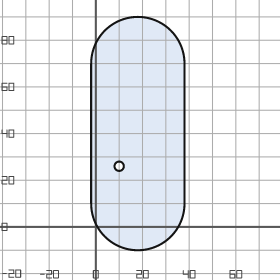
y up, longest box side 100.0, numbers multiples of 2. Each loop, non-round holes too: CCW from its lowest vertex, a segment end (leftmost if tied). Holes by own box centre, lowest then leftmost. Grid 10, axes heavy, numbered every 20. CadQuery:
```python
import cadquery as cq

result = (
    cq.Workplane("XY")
    .moveTo(-2.0, 10.0)
    .threePointArc((18.0, -10.0), (38.0, 10.0))
    .lineTo(38.0, 70.0)
    .threePointArc((18.0, 90.0), (-2.0, 70.0))
    .close()
    .moveTo(10.0, 26.0)
    .circle(2.0)
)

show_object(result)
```